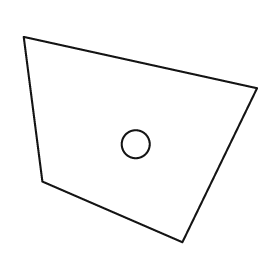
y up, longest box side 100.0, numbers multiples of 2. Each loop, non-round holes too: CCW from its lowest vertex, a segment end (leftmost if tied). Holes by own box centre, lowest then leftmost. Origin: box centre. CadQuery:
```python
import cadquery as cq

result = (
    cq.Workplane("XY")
    .moveTo(18.0, -44.0)
    .lineTo(50.0, 22.0)
    .lineTo(-50.0, 44.0)
    .lineTo(-42.0, -18.0)
    .close()
    .moveTo(-2.0, -2.0)
    .circle(6.0)
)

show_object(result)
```